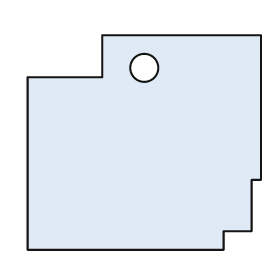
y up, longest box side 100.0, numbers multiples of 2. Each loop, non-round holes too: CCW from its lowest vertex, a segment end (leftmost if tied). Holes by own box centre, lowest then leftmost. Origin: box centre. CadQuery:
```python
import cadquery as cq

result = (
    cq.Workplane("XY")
    .moveTo(-50.0, -46.0)
    .lineTo(34.0, -46.0)
    .lineTo(34.0, -38.0)
    .lineTo(46.0, -38.0)
    .lineTo(46.0, -16.0)
    .lineTo(50.0, -16.0)
    .lineTo(50.0, 46.0)
    .lineTo(-18.0, 46.0)
    .lineTo(-18.0, 28.0)
    .lineTo(-50.0, 28.0)
    .close()
    .moveTo(0.0, 32.0)
    .circle(6.0)
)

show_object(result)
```